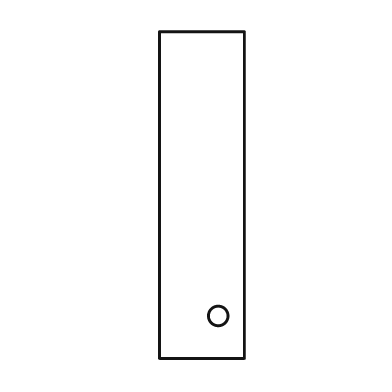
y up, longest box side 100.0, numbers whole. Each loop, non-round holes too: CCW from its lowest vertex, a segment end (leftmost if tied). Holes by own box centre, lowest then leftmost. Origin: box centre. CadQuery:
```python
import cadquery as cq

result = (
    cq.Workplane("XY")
    .moveTo(-13.0, -50.0)
    .lineTo(13.0, -50.0)
    .lineTo(13.0, 50.0)
    .lineTo(-13.0, 50.0)
    .close()
    .moveTo(5.0, -37.0)
    .circle(3.0)
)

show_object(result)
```